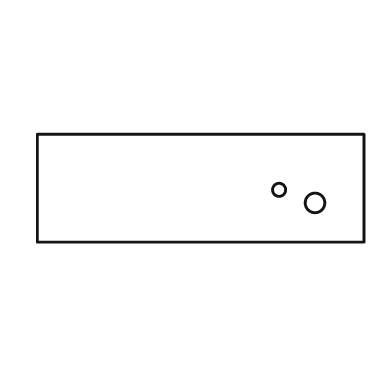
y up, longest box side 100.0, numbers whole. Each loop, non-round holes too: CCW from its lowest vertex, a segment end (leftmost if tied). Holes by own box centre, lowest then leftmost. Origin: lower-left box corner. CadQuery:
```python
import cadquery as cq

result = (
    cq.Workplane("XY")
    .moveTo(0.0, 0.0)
    .lineTo(100.0, 0.0)
    .lineTo(100.0, 33.0)
    .lineTo(0.0, 33.0)
    .close()
    .moveTo(85.0, 12.0)
    .circle(3.0)
    .moveTo(74.0, 16.0)
    .circle(2.0)
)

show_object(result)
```